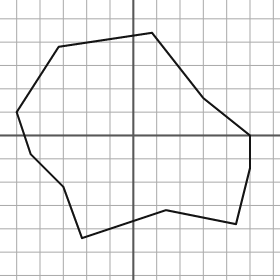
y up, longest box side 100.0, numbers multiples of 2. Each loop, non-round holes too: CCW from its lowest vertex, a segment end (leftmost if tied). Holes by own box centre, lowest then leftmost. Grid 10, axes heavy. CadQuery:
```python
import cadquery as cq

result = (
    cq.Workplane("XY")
    .moveTo(-22.0, -44.0)
    .lineTo(14.0, -32.0)
    .lineTo(44.0, -38.0)
    .lineTo(50.0, -14.0)
    .lineTo(50.0, 0.0)
    .lineTo(30.0, 16.0)
    .lineTo(8.0, 44.0)
    .lineTo(-32.0, 38.0)
    .lineTo(-50.0, 10.0)
    .lineTo(-44.0, -8.0)
    .lineTo(-30.0, -22.0)
    .close()
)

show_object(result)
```